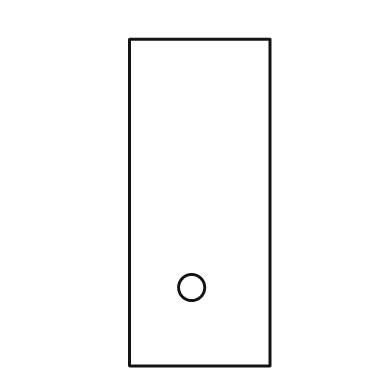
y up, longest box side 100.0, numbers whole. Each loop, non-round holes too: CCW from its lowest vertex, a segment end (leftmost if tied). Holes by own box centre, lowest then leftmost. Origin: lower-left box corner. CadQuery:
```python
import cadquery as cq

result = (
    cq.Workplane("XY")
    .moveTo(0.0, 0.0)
    .lineTo(43.0, 0.0)
    .lineTo(43.0, 100.0)
    .lineTo(0.0, 100.0)
    .close()
    .moveTo(19.0, 24.0)
    .circle(4.0)
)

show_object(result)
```